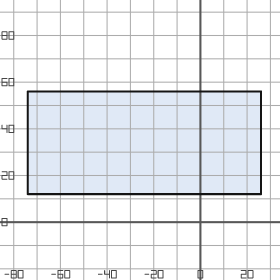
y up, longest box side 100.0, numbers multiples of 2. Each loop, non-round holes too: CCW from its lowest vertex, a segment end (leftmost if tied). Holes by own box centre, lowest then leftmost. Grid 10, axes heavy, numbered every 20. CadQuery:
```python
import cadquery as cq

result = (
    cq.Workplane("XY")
    .moveTo(-74.0, 12.0)
    .lineTo(26.0, 12.0)
    .lineTo(26.0, 56.0)
    .lineTo(-74.0, 56.0)
    .close()
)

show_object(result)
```